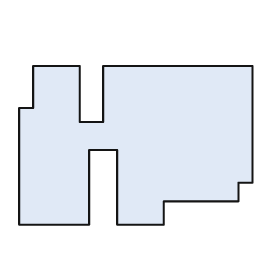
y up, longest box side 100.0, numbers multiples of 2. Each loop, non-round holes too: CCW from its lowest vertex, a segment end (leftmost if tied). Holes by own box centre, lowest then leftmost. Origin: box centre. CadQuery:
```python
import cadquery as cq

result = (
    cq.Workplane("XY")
    .moveTo(-50.0, -34.0)
    .lineTo(-20.0, -34.0)
    .lineTo(-20.0, -2.0)
    .lineTo(-8.0, -2.0)
    .lineTo(-8.0, -34.0)
    .lineTo(12.0, -34.0)
    .lineTo(12.0, -24.0)
    .lineTo(44.0, -24.0)
    .lineTo(44.0, -16.0)
    .lineTo(50.0, -16.0)
    .lineTo(50.0, 34.0)
    .lineTo(-14.0, 34.0)
    .lineTo(-14.0, 10.0)
    .lineTo(-24.0, 10.0)
    .lineTo(-24.0, 34.0)
    .lineTo(-44.0, 34.0)
    .lineTo(-44.0, 16.0)
    .lineTo(-50.0, 16.0)
    .close()
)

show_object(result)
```